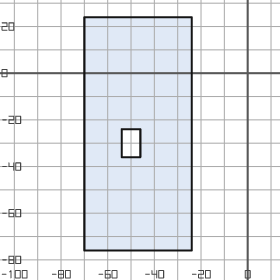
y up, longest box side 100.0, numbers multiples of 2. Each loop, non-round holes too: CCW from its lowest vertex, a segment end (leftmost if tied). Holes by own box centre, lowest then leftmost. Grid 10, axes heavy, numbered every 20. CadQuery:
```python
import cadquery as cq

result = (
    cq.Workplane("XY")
    .moveTo(-70.0, -76.0)
    .lineTo(-24.0, -76.0)
    .lineTo(-24.0, 24.0)
    .lineTo(-70.0, 24.0)
    .close()
    .moveTo(-54.0, -36.0)
    .lineTo(-46.0, -36.0)
    .lineTo(-46.0, -24.0)
    .lineTo(-54.0, -24.0)
    .close()
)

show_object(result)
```